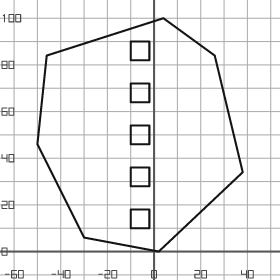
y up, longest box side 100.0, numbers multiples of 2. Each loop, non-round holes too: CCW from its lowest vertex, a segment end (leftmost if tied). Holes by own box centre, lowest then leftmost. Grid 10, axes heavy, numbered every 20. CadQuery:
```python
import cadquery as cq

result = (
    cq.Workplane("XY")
    .moveTo(2.0, 0.0)
    .lineTo(38.0, 34.0)
    .lineTo(26.0, 84.0)
    .lineTo(4.0, 100.0)
    .lineTo(-46.0, 84.0)
    .lineTo(-50.0, 46.0)
    .lineTo(-30.0, 6.0)
    .close()
    .moveTo(-10.0, 10.0)
    .lineTo(-2.0, 10.0)
    .lineTo(-2.0, 18.0)
    .lineTo(-10.0, 18.0)
    .close()
    .moveTo(-10.0, 28.0)
    .lineTo(-2.0, 28.0)
    .lineTo(-2.0, 36.0)
    .lineTo(-10.0, 36.0)
    .close()
    .moveTo(-10.0, 46.0)
    .lineTo(-2.0, 46.0)
    .lineTo(-2.0, 54.0)
    .lineTo(-10.0, 54.0)
    .close()
    .moveTo(-10.0, 64.0)
    .lineTo(-2.0, 64.0)
    .lineTo(-2.0, 72.0)
    .lineTo(-10.0, 72.0)
    .close()
    .moveTo(-10.0, 82.0)
    .lineTo(-2.0, 82.0)
    .lineTo(-2.0, 90.0)
    .lineTo(-10.0, 90.0)
    .close()
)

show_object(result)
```